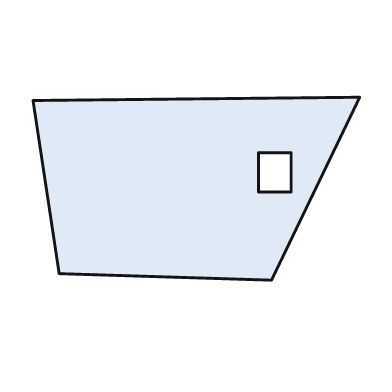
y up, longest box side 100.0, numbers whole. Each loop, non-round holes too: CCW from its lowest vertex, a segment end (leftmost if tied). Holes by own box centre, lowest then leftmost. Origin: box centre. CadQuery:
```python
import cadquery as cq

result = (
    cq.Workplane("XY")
    .moveTo(23.0, -28.0)
    .lineTo(50.0, 28.0)
    .lineTo(-50.0, 27.0)
    .lineTo(-42.0, -26.0)
    .close()
    .moveTo(19.0, -1.0)
    .lineTo(29.0, -1.0)
    .lineTo(29.0, 11.0)
    .lineTo(19.0, 11.0)
    .close()
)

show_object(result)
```